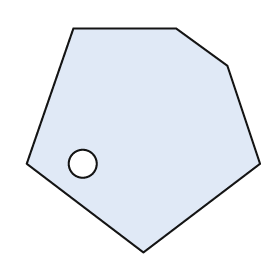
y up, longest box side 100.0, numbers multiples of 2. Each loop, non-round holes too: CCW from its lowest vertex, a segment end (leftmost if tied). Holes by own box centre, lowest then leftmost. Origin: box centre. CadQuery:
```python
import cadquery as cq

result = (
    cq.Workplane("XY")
    .moveTo(0.0, -48.0)
    .lineTo(50.0, -10.0)
    .lineTo(36.0, 32.0)
    .lineTo(14.0, 48.0)
    .lineTo(-30.0, 48.0)
    .lineTo(-50.0, -10.0)
    .close()
    .moveTo(-26.0, -10.0)
    .circle(6.0)
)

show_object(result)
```